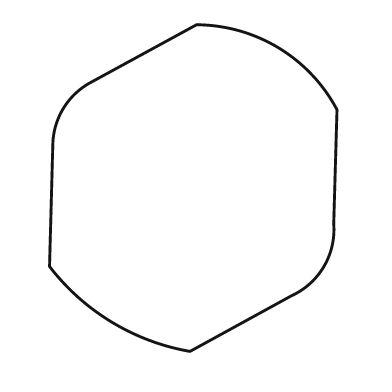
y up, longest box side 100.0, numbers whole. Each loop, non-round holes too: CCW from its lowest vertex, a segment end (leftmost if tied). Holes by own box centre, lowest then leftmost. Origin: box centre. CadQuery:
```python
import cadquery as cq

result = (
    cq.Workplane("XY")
    .moveTo(-1.0, -50.0)
    .lineTo(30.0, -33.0)
    .threePointArc((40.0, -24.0), (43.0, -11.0))
    .lineTo(44.0, 24.0)
    .threePointArc((26.0, 43.0), (1.0, 50.0))
    .lineTo(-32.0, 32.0)
    .threePointArc((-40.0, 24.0), (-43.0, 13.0))
    .lineTo(-44.0, -24.0)
    .threePointArc((-25.0, -41.0), (-1.0, -50.0))
    .close()
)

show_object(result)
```